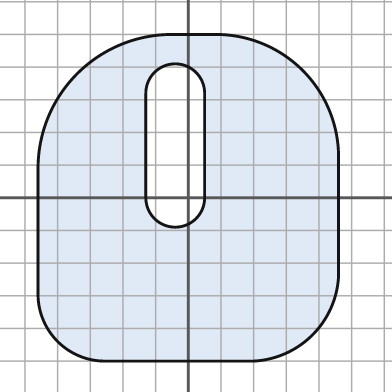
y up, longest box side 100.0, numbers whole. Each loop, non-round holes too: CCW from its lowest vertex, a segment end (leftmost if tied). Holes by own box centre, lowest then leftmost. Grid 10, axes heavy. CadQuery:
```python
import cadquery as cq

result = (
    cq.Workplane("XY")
    .moveTo(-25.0, -50.0)
    .lineTo(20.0, -50.0)
    .threePointArc((38.0, -42.0), (46.0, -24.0))
    .lineTo(46.0, 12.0)
    .threePointArc((35.0, 39.0), (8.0, 50.0))
    .lineTo(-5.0, 50.0)
    .threePointArc((-34.0, 38.0), (-46.0, 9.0))
    .lineTo(-46.0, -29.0)
    .threePointArc((-40.0, -44.0), (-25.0, -50.0))
    .close()
    .moveTo(-13.0, 0.0)
    .threePointArc((-4.0, -9.0), (5.0, 0.0))
    .lineTo(5.0, 32.0)
    .threePointArc((-4.0, 41.0), (-13.0, 32.0))
    .close()
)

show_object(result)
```